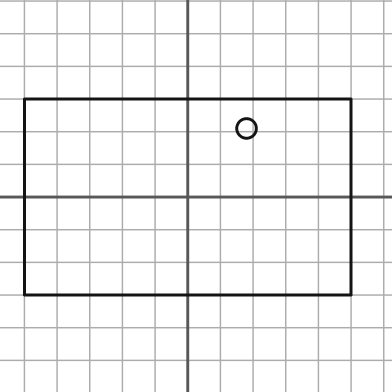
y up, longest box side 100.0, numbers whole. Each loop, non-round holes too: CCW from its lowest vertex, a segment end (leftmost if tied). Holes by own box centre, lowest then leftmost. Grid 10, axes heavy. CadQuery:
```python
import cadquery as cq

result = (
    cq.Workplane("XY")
    .moveTo(-50.0, -30.0)
    .lineTo(50.0, -30.0)
    .lineTo(50.0, 30.0)
    .lineTo(-50.0, 30.0)
    .close()
    .moveTo(18.0, 21.0)
    .circle(3.0)
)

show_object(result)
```